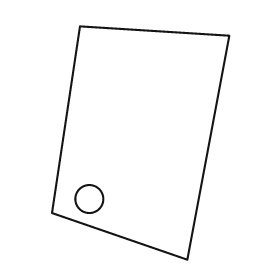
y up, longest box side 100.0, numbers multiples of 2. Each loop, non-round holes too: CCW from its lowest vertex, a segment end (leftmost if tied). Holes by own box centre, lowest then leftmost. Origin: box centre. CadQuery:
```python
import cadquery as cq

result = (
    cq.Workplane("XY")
    .moveTo(20.0, -50.0)
    .lineTo(38.0, 46.0)
    .lineTo(-26.0, 50.0)
    .lineTo(-38.0, -30.0)
    .close()
    .moveTo(-22.0, -24.0)
    .circle(6.0)
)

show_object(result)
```